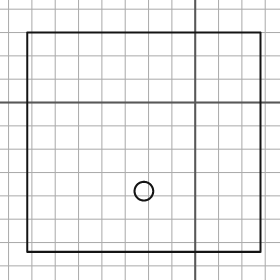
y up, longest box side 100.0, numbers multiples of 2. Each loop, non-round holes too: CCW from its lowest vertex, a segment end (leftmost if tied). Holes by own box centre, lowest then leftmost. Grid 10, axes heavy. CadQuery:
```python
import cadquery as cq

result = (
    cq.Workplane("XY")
    .moveTo(-72.0, -64.0)
    .lineTo(28.0, -64.0)
    .lineTo(28.0, 30.0)
    .lineTo(-72.0, 30.0)
    .close()
    .moveTo(-22.0, -38.0)
    .circle(4.0)
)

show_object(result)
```